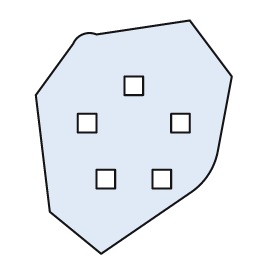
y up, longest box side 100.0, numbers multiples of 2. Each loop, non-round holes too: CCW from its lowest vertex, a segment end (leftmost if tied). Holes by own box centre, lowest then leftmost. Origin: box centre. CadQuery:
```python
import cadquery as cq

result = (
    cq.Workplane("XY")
    .moveTo(-14.0, -50.0)
    .lineTo(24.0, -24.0)
    .threePointArc((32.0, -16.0), (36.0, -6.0))
    .lineTo(42.0, 26.0)
    .lineTo(24.0, 50.0)
    .lineTo(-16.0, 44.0)
    .threePointArc((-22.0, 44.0), (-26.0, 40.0))
    .lineTo(-42.0, 18.0)
    .lineTo(-36.0, -32.0)
    .close()
    .moveTo(-16.0, -22.0)
    .lineTo(-8.0, -22.0)
    .lineTo(-8.0, -14.0)
    .lineTo(-16.0, -14.0)
    .close()
    .moveTo(8.0, -22.0)
    .lineTo(16.0, -22.0)
    .lineTo(16.0, -14.0)
    .lineTo(8.0, -14.0)
    .close()
    .moveTo(-24.0, 2.0)
    .lineTo(-16.0, 2.0)
    .lineTo(-16.0, 10.0)
    .lineTo(-24.0, 10.0)
    .close()
    .moveTo(16.0, 2.0)
    .lineTo(24.0, 2.0)
    .lineTo(24.0, 10.0)
    .lineTo(16.0, 10.0)
    .close()
    .moveTo(-4.0, 18.0)
    .lineTo(4.0, 18.0)
    .lineTo(4.0, 26.0)
    .lineTo(-4.0, 26.0)
    .close()
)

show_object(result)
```